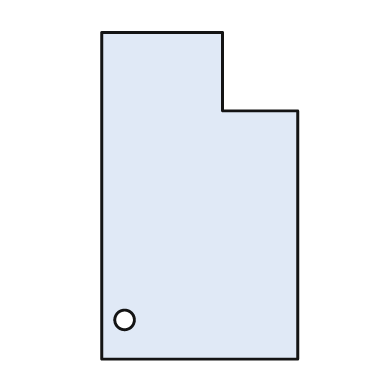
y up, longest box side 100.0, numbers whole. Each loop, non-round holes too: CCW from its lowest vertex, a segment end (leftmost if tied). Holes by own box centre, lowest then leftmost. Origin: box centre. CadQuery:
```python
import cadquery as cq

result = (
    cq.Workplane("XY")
    .moveTo(-30.0, -50.0)
    .lineTo(30.0, -50.0)
    .lineTo(30.0, 26.0)
    .lineTo(7.0, 26.0)
    .lineTo(7.0, 50.0)
    .lineTo(-30.0, 50.0)
    .close()
    .moveTo(-23.0, -38.0)
    .circle(3.0)
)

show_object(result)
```